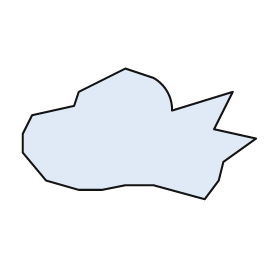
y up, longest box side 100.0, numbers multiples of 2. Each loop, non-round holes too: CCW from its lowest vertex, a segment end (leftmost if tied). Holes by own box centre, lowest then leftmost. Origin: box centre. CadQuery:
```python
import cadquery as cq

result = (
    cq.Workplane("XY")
    .moveTo(28.0, -28.0)
    .lineTo(34.0, -20.0)
    .lineTo(36.0, -12.0)
    .lineTo(50.0, -2.0)
    .lineTo(32.0, 2.0)
    .lineTo(40.0, 18.0)
    .lineTo(14.0, 10.0)
    .threePointArc((12.0, 18.0), (6.0, 24.0))
    .lineTo(-6.0, 28.0)
    .lineTo(-26.0, 18.0)
    .lineTo(-28.0, 12.0)
    .lineTo(-46.0, 8.0)
    .lineTo(-50.0, 0.0)
    .lineTo(-50.0, -8.0)
    .lineTo(-40.0, -20.0)
    .lineTo(-26.0, -24.0)
    .lineTo(-16.0, -24.0)
    .lineTo(-6.0, -22.0)
    .lineTo(6.0, -22.0)
    .close()
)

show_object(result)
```